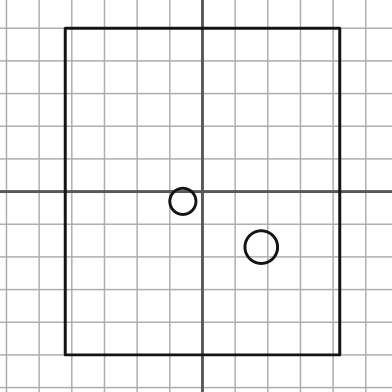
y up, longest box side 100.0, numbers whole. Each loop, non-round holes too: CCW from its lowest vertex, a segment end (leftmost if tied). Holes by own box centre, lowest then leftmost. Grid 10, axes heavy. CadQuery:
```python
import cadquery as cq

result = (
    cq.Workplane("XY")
    .moveTo(-42.0, -50.0)
    .lineTo(42.0, -50.0)
    .lineTo(42.0, 50.0)
    .lineTo(-42.0, 50.0)
    .close()
    .moveTo(18.0, -17.0)
    .circle(5.0)
    .moveTo(-6.0, -3.0)
    .circle(4.0)
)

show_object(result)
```